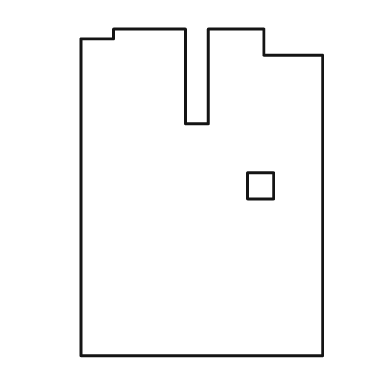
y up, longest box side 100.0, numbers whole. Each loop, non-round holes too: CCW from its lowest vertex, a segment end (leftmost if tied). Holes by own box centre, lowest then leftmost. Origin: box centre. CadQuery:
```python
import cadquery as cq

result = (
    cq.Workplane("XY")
    .moveTo(-37.0, -50.0)
    .lineTo(37.0, -50.0)
    .lineTo(37.0, 42.0)
    .lineTo(19.0, 42.0)
    .lineTo(19.0, 50.0)
    .lineTo(2.0, 50.0)
    .lineTo(2.0, 21.0)
    .lineTo(-5.0, 21.0)
    .lineTo(-5.0, 50.0)
    .lineTo(-27.0, 50.0)
    .lineTo(-27.0, 47.0)
    .lineTo(-37.0, 47.0)
    .close()
    .moveTo(14.0, -2.0)
    .lineTo(22.0, -2.0)
    .lineTo(22.0, 6.0)
    .lineTo(14.0, 6.0)
    .close()
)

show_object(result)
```